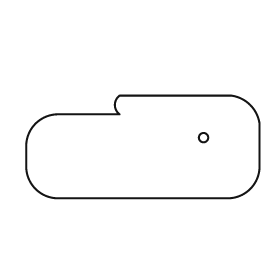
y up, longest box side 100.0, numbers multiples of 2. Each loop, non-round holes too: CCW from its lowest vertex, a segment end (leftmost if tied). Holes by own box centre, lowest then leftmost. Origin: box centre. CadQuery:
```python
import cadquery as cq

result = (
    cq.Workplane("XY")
    .moveTo(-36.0, -22.0)
    .lineTo(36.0, -22.0)
    .threePointArc((46.0, -18.0), (50.0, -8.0))
    .lineTo(50.0, 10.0)
    .threePointArc((46.0, 18.0), (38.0, 22.0))
    .lineTo(-10.0, 22.0)
    .threePointArc((-12.0, 18.0), (-10.0, 14.0))
    .lineTo(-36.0, 14.0)
    .threePointArc((-46.0, 10.0), (-50.0, 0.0))
    .lineTo(-50.0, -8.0)
    .threePointArc((-46.0, -18.0), (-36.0, -22.0))
    .close()
    .moveTo(26.0, 4.0)
    .circle(2.0)
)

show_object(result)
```